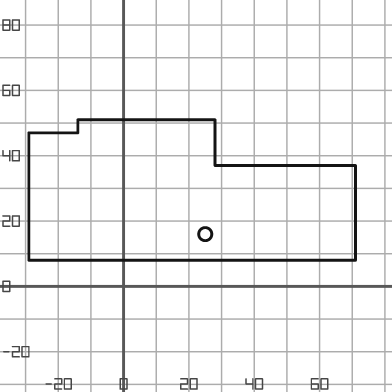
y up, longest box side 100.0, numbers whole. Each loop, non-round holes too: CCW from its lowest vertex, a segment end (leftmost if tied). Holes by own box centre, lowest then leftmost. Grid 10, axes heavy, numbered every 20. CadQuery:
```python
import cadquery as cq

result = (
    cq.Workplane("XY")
    .moveTo(-29.0, 8.0)
    .lineTo(71.0, 8.0)
    .lineTo(71.0, 37.0)
    .lineTo(28.0, 37.0)
    .lineTo(28.0, 51.0)
    .lineTo(-14.0, 51.0)
    .lineTo(-14.0, 47.0)
    .lineTo(-29.0, 47.0)
    .close()
    .moveTo(25.0, 16.0)
    .circle(2.0)
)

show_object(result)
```